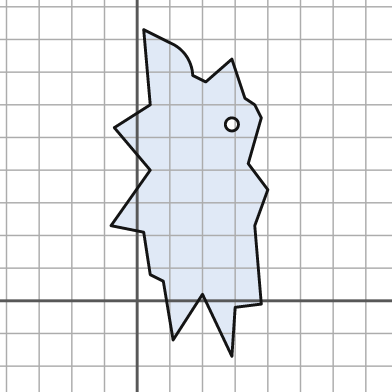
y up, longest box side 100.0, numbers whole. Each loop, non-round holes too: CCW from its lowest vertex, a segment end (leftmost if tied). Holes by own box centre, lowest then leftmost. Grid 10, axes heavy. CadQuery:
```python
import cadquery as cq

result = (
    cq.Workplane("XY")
    .moveTo(29.0, -17.0)
    .lineTo(30.0, -2.0)
    .lineTo(38.0, -1.0)
    .lineTo(36.0, 23.0)
    .lineTo(40.0, 34.0)
    .lineTo(34.0, 42.0)
    .lineTo(38.0, 56.0)
    .lineTo(36.0, 60.0)
    .lineTo(33.0, 62.0)
    .lineTo(29.0, 74.0)
    .lineTo(21.0, 67.0)
    .lineTo(17.0, 69.0)
    .threePointArc((15.0, 75.0), (10.0, 79.0))
    .lineTo(2.0, 83.0)
    .lineTo(4.0, 60.0)
    .lineTo(-7.0, 53.0)
    .lineTo(4.0, 40.0)
    .lineTo(-8.0, 23.0)
    .lineTo(2.0, 21.0)
    .lineTo(4.0, 8.0)
    .lineTo(8.0, 6.0)
    .lineTo(11.0, -12.0)
    .lineTo(20.0, 2.0)
    .close()
    .moveTo(29.0, 54.0)
    .circle(2.0)
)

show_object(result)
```